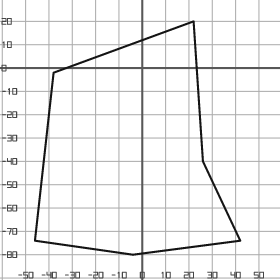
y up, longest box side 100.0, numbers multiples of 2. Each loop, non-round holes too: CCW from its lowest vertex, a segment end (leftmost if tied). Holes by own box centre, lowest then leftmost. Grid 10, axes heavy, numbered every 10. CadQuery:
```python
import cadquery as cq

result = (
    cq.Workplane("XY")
    .moveTo(-4.0, -80.0)
    .lineTo(42.0, -74.0)
    .lineTo(26.0, -40.0)
    .lineTo(22.0, 20.0)
    .lineTo(-38.0, -2.0)
    .lineTo(-46.0, -74.0)
    .close()
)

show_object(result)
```